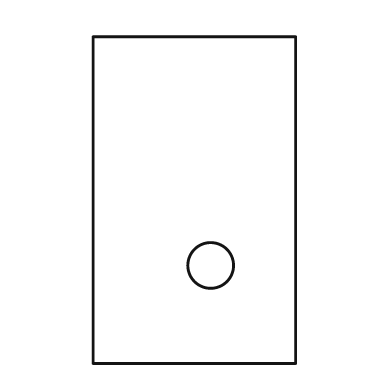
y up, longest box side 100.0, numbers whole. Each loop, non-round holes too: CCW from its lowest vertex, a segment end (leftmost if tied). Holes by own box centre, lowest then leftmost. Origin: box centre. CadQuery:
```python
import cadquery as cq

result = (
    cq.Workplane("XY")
    .moveTo(-31.0, -50.0)
    .lineTo(31.0, -50.0)
    .lineTo(31.0, 50.0)
    .lineTo(-31.0, 50.0)
    .close()
    .moveTo(5.0, -20.0)
    .circle(7.0)
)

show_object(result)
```